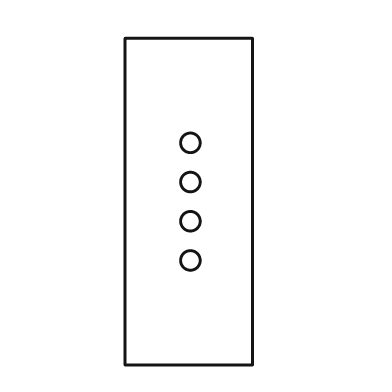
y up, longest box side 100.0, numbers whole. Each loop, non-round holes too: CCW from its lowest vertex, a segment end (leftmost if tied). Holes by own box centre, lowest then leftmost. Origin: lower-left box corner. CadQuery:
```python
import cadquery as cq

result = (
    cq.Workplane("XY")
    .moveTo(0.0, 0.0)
    .lineTo(39.0, 0.0)
    .lineTo(39.0, 100.0)
    .lineTo(0.0, 100.0)
    .close()
    .moveTo(20.0, 32.0)
    .circle(3.0)
    .moveTo(20.0, 44.0)
    .circle(3.0)
    .moveTo(20.0, 56.0)
    .circle(3.0)
    .moveTo(20.0, 68.0)
    .circle(3.0)
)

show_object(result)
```